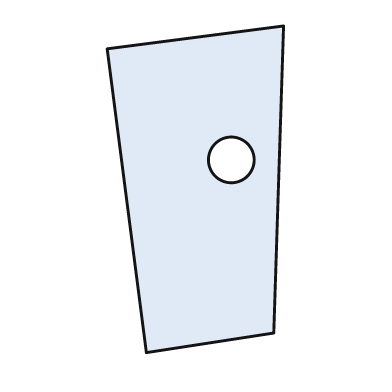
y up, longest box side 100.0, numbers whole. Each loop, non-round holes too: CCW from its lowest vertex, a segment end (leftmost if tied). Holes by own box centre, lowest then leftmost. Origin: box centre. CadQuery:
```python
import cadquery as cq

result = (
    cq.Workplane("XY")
    .moveTo(-15.0, -50.0)
    .lineTo(24.0, -44.0)
    .lineTo(27.0, 50.0)
    .lineTo(-27.0, 43.0)
    .close()
    .moveTo(11.0, 9.0)
    .circle(7.0)
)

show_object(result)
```